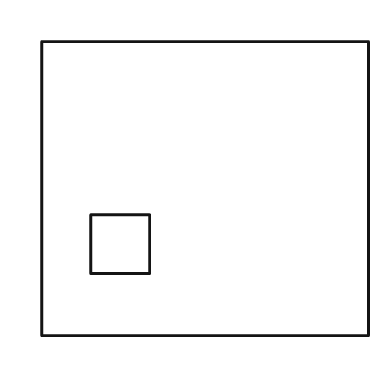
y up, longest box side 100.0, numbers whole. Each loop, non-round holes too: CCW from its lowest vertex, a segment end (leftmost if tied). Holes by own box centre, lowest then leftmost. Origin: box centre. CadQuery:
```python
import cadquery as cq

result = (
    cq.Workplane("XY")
    .moveTo(-50.0, -45.0)
    .lineTo(50.0, -45.0)
    .lineTo(50.0, 45.0)
    .lineTo(-50.0, 45.0)
    .close()
    .moveTo(-35.0, -26.0)
    .lineTo(-17.0, -26.0)
    .lineTo(-17.0, -8.0)
    .lineTo(-35.0, -8.0)
    .close()
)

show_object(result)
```